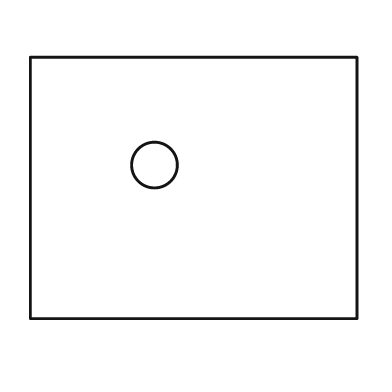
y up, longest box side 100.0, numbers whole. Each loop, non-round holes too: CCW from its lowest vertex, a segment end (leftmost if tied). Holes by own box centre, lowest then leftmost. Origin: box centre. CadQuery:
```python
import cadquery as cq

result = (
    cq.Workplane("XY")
    .moveTo(-50.0, -40.0)
    .lineTo(50.0, -40.0)
    .lineTo(50.0, 40.0)
    .lineTo(-50.0, 40.0)
    .close()
    .moveTo(-12.0, 7.0)
    .circle(7.0)
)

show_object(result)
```